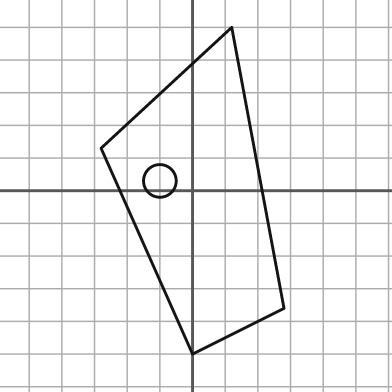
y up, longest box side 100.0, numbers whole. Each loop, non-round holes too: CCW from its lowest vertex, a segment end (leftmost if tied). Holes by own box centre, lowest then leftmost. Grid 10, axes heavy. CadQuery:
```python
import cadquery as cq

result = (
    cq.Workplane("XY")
    .moveTo(0.0, -50.0)
    .lineTo(28.0, -36.0)
    .lineTo(12.0, 50.0)
    .lineTo(-28.0, 13.0)
    .close()
    .moveTo(-10.0, 3.0)
    .circle(5.0)
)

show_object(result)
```